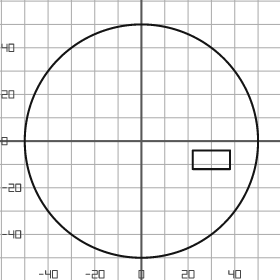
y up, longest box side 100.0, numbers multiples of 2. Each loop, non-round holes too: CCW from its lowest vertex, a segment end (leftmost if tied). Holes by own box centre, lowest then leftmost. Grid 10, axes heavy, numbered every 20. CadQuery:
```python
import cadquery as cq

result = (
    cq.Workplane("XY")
    .moveTo(0.0, 0.0)
    .circle(50.0)
    .moveTo(22.0, -12.0)
    .lineTo(38.0, -12.0)
    .lineTo(38.0, -4.0)
    .lineTo(22.0, -4.0)
    .close()
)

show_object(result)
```